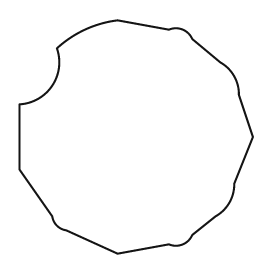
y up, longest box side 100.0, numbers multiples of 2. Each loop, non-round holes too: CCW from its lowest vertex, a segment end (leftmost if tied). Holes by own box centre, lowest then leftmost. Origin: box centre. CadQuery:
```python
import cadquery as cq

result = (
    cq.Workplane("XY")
    .moveTo(-8.0, -50.0)
    .lineTo(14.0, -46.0)
    .threePointArc((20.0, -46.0), (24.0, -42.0))
    .lineTo(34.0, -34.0)
    .threePointArc((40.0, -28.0), (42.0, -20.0))
    .lineTo(50.0, 0.0)
    .lineTo(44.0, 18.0)
    .threePointArc((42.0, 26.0), (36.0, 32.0))
    .lineTo(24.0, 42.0)
    .threePointArc((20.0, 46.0), (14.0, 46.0))
    .lineTo(-8.0, 50.0)
    .threePointArc((-22.0, 46.0), (-34.0, 38.0))
    .threePointArc((-36.0, 22.0), (-50.0, 14.0))
    .lineTo(-50.0, -14.0)
    .lineTo(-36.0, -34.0)
    .threePointArc((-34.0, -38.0), (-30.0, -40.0))
    .close()
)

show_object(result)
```